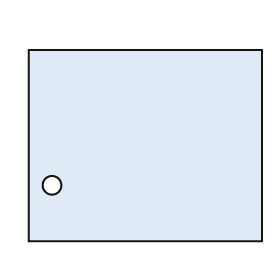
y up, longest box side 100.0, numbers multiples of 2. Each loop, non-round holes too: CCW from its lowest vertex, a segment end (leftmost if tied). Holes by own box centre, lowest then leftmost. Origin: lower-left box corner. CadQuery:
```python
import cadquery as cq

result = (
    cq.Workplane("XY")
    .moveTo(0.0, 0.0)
    .lineTo(100.0, 0.0)
    .lineTo(100.0, 82.0)
    .lineTo(0.0, 82.0)
    .close()
    .moveTo(10.0, 24.0)
    .circle(4.0)
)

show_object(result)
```